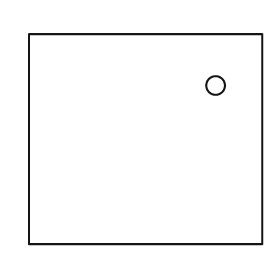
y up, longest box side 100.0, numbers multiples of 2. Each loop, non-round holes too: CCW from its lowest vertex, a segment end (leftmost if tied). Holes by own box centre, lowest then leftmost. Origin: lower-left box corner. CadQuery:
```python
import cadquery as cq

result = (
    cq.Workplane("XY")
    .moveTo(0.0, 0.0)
    .lineTo(100.0, 0.0)
    .lineTo(100.0, 90.0)
    .lineTo(0.0, 90.0)
    .close()
    .moveTo(80.0, 68.0)
    .circle(4.0)
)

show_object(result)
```